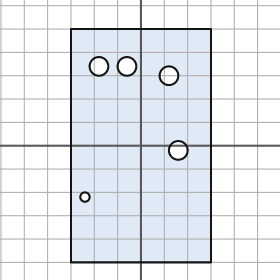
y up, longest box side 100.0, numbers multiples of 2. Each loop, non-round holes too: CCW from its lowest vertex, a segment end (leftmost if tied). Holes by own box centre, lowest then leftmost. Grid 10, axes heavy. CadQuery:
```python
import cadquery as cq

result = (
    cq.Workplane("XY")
    .moveTo(-30.0, -50.0)
    .lineTo(30.0, -50.0)
    .lineTo(30.0, 50.0)
    .lineTo(-30.0, 50.0)
    .close()
    .moveTo(-24.0, -22.0)
    .circle(2.0)
    .moveTo(16.0, -2.0)
    .circle(4.0)
    .moveTo(12.0, 30.0)
    .circle(4.0)
    .moveTo(-18.0, 34.0)
    .circle(4.0)
    .moveTo(-6.0, 34.0)
    .circle(4.0)
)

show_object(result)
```